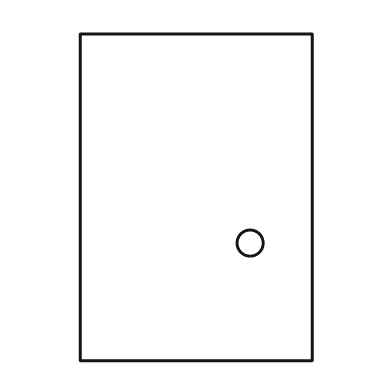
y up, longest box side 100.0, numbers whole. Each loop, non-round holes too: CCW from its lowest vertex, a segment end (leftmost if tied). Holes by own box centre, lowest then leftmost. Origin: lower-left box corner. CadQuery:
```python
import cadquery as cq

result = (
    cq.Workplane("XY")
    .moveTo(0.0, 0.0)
    .lineTo(71.0, 0.0)
    .lineTo(71.0, 100.0)
    .lineTo(0.0, 100.0)
    .close()
    .moveTo(52.0, 36.0)
    .circle(4.0)
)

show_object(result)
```